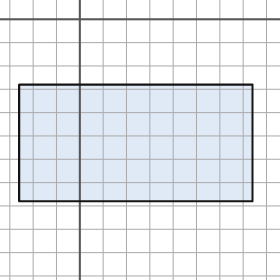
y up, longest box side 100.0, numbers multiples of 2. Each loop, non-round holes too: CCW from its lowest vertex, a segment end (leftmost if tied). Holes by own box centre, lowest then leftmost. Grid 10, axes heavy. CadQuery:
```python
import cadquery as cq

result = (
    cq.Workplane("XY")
    .moveTo(-26.0, -78.0)
    .lineTo(74.0, -78.0)
    .lineTo(74.0, -28.0)
    .lineTo(-26.0, -28.0)
    .close()
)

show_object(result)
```